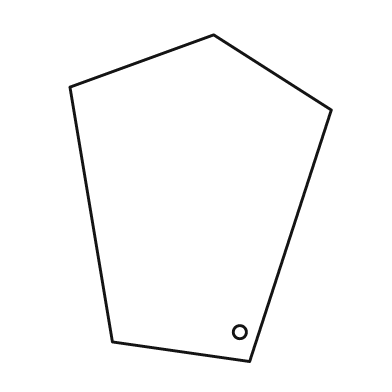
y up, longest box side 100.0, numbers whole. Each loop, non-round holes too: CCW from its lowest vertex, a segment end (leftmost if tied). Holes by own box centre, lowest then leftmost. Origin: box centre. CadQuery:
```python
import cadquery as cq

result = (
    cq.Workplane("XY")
    .moveTo(15.0, -50.0)
    .lineTo(40.0, 27.0)
    .lineTo(4.0, 50.0)
    .lineTo(-40.0, 34.0)
    .lineTo(-27.0, -44.0)
    .close()
    .moveTo(12.0, -41.0)
    .circle(2.0)
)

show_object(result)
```